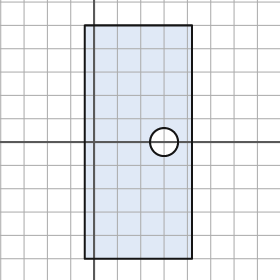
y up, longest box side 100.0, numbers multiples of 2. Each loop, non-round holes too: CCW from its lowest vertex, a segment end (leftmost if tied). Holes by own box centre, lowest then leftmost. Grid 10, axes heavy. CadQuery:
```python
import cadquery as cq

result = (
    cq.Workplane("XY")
    .moveTo(-4.0, -50.0)
    .lineTo(42.0, -50.0)
    .lineTo(42.0, 50.0)
    .lineTo(-4.0, 50.0)
    .close()
    .moveTo(30.0, 0.0)
    .circle(6.0)
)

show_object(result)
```